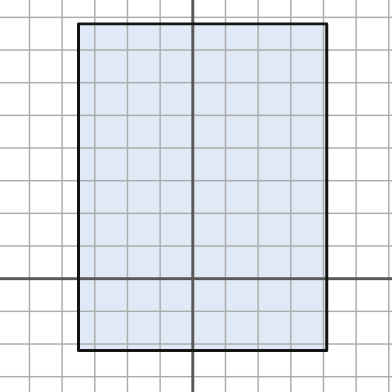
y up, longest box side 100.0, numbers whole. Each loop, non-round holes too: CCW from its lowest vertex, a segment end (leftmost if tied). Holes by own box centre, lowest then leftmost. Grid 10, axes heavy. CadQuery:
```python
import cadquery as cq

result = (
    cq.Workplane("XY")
    .moveTo(-35.0, -22.0)
    .lineTo(41.0, -22.0)
    .lineTo(41.0, 78.0)
    .lineTo(-35.0, 78.0)
    .close()
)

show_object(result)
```